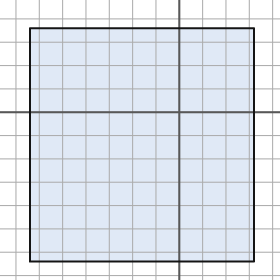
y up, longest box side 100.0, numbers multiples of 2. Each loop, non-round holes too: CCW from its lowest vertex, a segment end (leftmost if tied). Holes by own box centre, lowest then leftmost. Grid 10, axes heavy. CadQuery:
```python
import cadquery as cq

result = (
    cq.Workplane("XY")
    .moveTo(-64.0, -64.0)
    .lineTo(32.0, -64.0)
    .lineTo(32.0, 36.0)
    .lineTo(-64.0, 36.0)
    .close()
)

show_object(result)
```